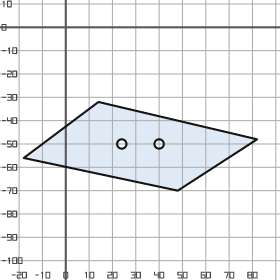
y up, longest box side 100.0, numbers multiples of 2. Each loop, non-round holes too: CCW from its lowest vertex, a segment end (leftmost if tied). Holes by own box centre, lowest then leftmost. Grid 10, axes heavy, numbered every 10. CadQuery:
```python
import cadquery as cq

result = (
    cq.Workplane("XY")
    .moveTo(48.0, -70.0)
    .lineTo(82.0, -48.0)
    .lineTo(14.0, -32.0)
    .lineTo(-18.0, -56.0)
    .close()
    .moveTo(24.0, -50.0)
    .circle(2.0)
    .moveTo(40.0, -50.0)
    .circle(2.0)
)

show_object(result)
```